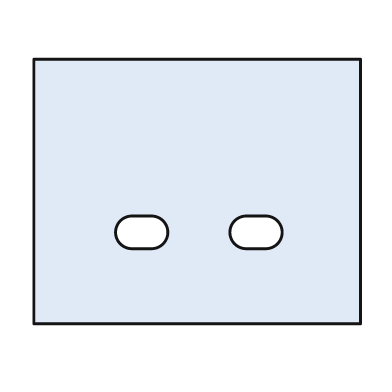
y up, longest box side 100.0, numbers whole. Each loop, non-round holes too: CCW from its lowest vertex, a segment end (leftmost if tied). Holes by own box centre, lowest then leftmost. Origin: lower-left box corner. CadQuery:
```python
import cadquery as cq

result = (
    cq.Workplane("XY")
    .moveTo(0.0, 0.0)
    .lineTo(100.0, 0.0)
    .lineTo(100.0, 81.0)
    .lineTo(0.0, 81.0)
    .close()
    .moveTo(30.0, 23.0)
    .lineTo(36.0, 23.0)
    .threePointArc((41.0, 28.0), (36.0, 33.0))
    .lineTo(30.0, 33.0)
    .threePointArc((25.0, 28.0), (30.0, 23.0))
    .close()
    .moveTo(65.0, 23.0)
    .lineTo(71.0, 23.0)
    .threePointArc((76.0, 28.0), (71.0, 33.0))
    .lineTo(65.0, 33.0)
    .threePointArc((60.0, 28.0), (65.0, 23.0))
    .close()
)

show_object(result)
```